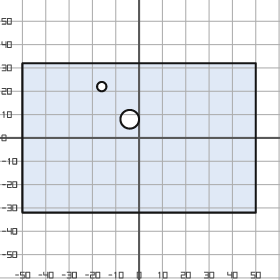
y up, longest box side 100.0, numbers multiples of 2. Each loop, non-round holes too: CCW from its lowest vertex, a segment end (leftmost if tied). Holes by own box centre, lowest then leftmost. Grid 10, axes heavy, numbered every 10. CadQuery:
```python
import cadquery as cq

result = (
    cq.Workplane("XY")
    .moveTo(-50.0, -32.0)
    .lineTo(50.0, -32.0)
    .lineTo(50.0, 32.0)
    .lineTo(-50.0, 32.0)
    .close()
    .moveTo(-4.0, 8.0)
    .circle(4.0)
    .moveTo(-16.0, 22.0)
    .circle(2.0)
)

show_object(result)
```